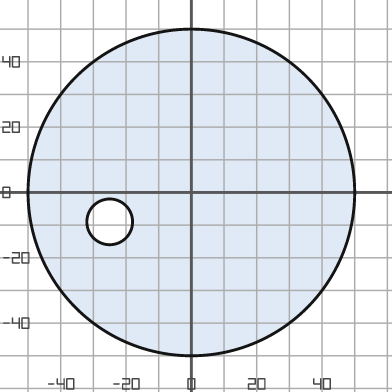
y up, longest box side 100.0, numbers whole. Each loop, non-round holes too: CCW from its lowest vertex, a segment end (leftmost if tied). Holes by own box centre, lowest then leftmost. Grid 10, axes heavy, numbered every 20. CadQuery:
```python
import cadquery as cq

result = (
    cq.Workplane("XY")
    .moveTo(0.0, 0.0)
    .circle(50.0)
    .moveTo(-25.0, -9.0)
    .circle(7.0)
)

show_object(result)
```